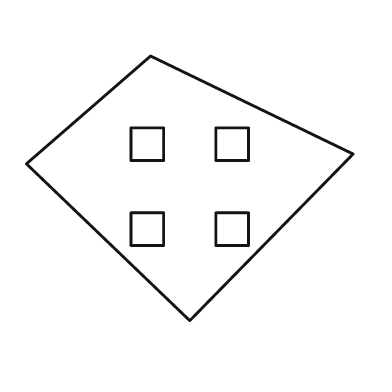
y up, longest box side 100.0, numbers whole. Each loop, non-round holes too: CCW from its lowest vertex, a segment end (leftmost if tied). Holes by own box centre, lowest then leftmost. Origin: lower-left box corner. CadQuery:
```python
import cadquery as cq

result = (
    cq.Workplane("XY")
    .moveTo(50.0, 0.0)
    .lineTo(100.0, 51.0)
    .lineTo(38.0, 81.0)
    .lineTo(0.0, 48.0)
    .close()
    .moveTo(32.0, 23.0)
    .lineTo(42.0, 23.0)
    .lineTo(42.0, 33.0)
    .lineTo(32.0, 33.0)
    .close()
    .moveTo(58.0, 23.0)
    .lineTo(68.0, 23.0)
    .lineTo(68.0, 33.0)
    .lineTo(58.0, 33.0)
    .close()
    .moveTo(32.0, 49.0)
    .lineTo(42.0, 49.0)
    .lineTo(42.0, 59.0)
    .lineTo(32.0, 59.0)
    .close()
    .moveTo(58.0, 49.0)
    .lineTo(68.0, 49.0)
    .lineTo(68.0, 59.0)
    .lineTo(58.0, 59.0)
    .close()
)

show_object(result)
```